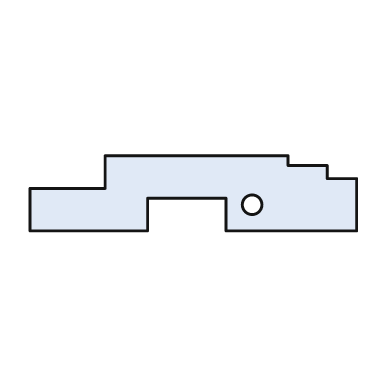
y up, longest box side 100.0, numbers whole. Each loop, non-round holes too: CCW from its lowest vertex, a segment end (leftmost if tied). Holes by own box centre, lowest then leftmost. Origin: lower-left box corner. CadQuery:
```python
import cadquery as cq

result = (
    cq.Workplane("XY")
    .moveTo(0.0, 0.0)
    .lineTo(36.0, 0.0)
    .lineTo(36.0, 10.0)
    .lineTo(60.0, 10.0)
    .lineTo(60.0, 0.0)
    .lineTo(100.0, 0.0)
    .lineTo(100.0, 16.0)
    .lineTo(91.0, 16.0)
    .lineTo(91.0, 20.0)
    .lineTo(79.0, 20.0)
    .lineTo(79.0, 23.0)
    .lineTo(23.0, 23.0)
    .lineTo(23.0, 13.0)
    .lineTo(0.0, 13.0)
    .close()
    .moveTo(68.0, 8.0)
    .circle(3.0)
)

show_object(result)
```